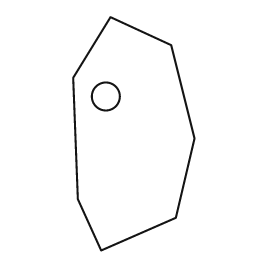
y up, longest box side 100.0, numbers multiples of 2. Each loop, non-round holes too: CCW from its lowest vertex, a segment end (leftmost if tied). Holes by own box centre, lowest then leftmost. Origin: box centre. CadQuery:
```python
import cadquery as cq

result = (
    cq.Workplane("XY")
    .moveTo(-14.0, -50.0)
    .lineTo(18.0, -36.0)
    .lineTo(26.0, -2.0)
    .lineTo(16.0, 38.0)
    .lineTo(-10.0, 50.0)
    .lineTo(-26.0, 24.0)
    .lineTo(-24.0, -28.0)
    .close()
    .moveTo(-12.0, 16.0)
    .circle(6.0)
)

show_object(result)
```